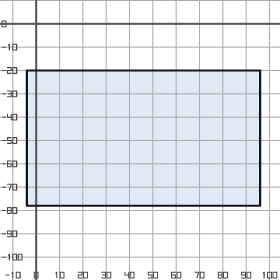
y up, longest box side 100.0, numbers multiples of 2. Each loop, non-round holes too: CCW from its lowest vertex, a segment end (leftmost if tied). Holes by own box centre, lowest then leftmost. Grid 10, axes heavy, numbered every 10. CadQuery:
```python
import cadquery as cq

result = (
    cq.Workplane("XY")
    .moveTo(-4.0, -78.0)
    .lineTo(96.0, -78.0)
    .lineTo(96.0, -20.0)
    .lineTo(-4.0, -20.0)
    .close()
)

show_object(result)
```